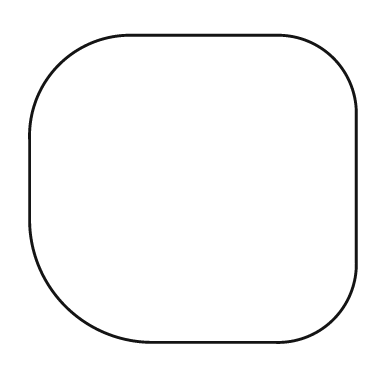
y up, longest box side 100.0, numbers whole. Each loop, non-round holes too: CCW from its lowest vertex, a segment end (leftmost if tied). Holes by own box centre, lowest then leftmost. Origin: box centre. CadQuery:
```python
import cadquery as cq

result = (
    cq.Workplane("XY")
    .moveTo(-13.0, -47.0)
    .lineTo(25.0, -47.0)
    .threePointArc((43.0, -40.0), (50.0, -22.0))
    .lineTo(50.0, 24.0)
    .threePointArc((43.0, 40.0), (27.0, 47.0))
    .lineTo(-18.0, 47.0)
    .threePointArc((-41.0, 38.0), (-50.0, 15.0))
    .lineTo(-50.0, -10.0)
    .threePointArc((-39.0, -36.0), (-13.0, -47.0))
    .close()
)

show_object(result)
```